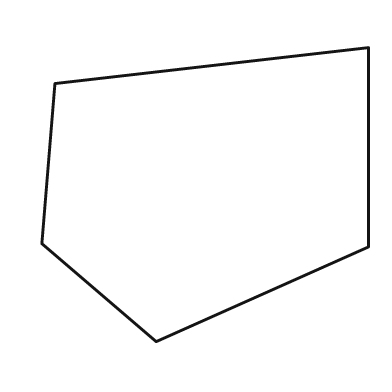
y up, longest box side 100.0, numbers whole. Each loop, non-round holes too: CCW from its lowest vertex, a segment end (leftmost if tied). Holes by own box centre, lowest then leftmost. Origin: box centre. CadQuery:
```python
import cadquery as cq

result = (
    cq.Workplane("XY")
    .moveTo(-15.0, -45.0)
    .lineTo(50.0, -16.0)
    .lineTo(50.0, 45.0)
    .lineTo(-46.0, 34.0)
    .lineTo(-50.0, -15.0)
    .close()
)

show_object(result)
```